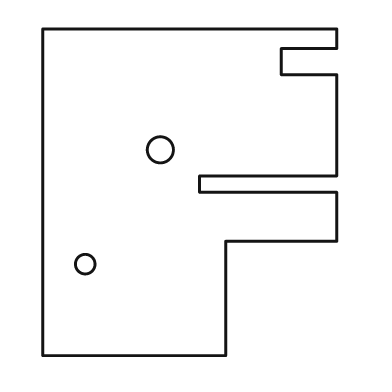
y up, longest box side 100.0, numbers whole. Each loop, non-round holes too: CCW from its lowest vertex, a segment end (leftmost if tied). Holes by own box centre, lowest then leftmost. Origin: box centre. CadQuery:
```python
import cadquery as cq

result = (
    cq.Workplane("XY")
    .moveTo(-45.0, -50.0)
    .lineTo(11.0, -50.0)
    .lineTo(11.0, -15.0)
    .lineTo(45.0, -15.0)
    .lineTo(45.0, 0.0)
    .lineTo(3.0, 0.0)
    .lineTo(3.0, 5.0)
    .lineTo(45.0, 5.0)
    .lineTo(45.0, 36.0)
    .lineTo(28.0, 36.0)
    .lineTo(28.0, 44.0)
    .lineTo(45.0, 44.0)
    .lineTo(45.0, 50.0)
    .lineTo(-45.0, 50.0)
    .close()
    .moveTo(-32.0, -22.0)
    .circle(3.0)
    .moveTo(-9.0, 13.0)
    .circle(4.0)
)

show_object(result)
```